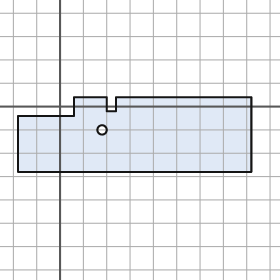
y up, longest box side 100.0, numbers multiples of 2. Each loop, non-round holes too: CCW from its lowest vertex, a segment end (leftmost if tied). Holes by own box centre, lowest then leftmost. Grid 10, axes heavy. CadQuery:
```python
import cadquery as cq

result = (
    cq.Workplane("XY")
    .moveTo(-18.0, -28.0)
    .lineTo(82.0, -28.0)
    .lineTo(82.0, 4.0)
    .lineTo(24.0, 4.0)
    .lineTo(24.0, -2.0)
    .lineTo(20.0, -2.0)
    .lineTo(20.0, 4.0)
    .lineTo(6.0, 4.0)
    .lineTo(6.0, -4.0)
    .lineTo(-18.0, -4.0)
    .close()
    .moveTo(18.0, -10.0)
    .circle(2.0)
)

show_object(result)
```